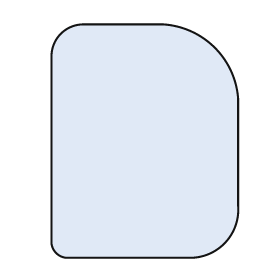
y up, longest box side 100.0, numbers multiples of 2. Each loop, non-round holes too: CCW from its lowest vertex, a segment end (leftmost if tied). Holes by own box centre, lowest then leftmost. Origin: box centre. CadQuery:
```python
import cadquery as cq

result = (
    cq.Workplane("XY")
    .moveTo(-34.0, -50.0)
    .lineTo(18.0, -50.0)
    .threePointArc((34.0, -44.0), (40.0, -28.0))
    .lineTo(40.0, 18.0)
    .threePointArc((30.0, 40.0), (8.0, 50.0))
    .lineTo(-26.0, 50.0)
    .threePointArc((-36.0, 46.0), (-40.0, 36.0))
    .lineTo(-40.0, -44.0)
    .threePointArc((-38.0, -48.0), (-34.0, -50.0))
    .close()
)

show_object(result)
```